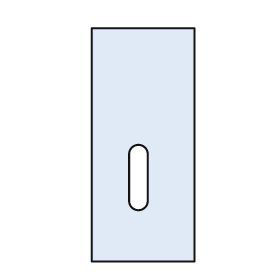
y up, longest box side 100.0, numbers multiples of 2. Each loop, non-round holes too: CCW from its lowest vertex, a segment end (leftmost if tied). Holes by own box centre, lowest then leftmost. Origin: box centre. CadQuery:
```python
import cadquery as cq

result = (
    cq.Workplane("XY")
    .moveTo(-22.0, -50.0)
    .lineTo(22.0, -50.0)
    .lineTo(22.0, 50.0)
    .lineTo(-22.0, 50.0)
    .close()
    .moveTo(-6.0, -24.0)
    .threePointArc((-2.0, -28.0), (2.0, -24.0))
    .lineTo(2.0, -4.0)
    .threePointArc((-2.0, 0.0), (-6.0, -4.0))
    .close()
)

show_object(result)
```